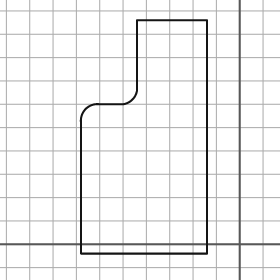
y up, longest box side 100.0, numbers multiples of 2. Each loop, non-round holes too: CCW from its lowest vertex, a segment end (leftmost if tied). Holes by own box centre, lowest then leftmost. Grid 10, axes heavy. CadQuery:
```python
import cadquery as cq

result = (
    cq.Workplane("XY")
    .moveTo(-68.0, -4.0)
    .lineTo(-14.0, -4.0)
    .lineTo(-14.0, 96.0)
    .lineTo(-44.0, 96.0)
    .lineTo(-44.0, 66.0)
    .threePointArc((-46.0, 62.0), (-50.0, 60.0))
    .lineTo(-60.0, 60.0)
    .threePointArc((-66.0, 58.0), (-68.0, 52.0))
    .close()
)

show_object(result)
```